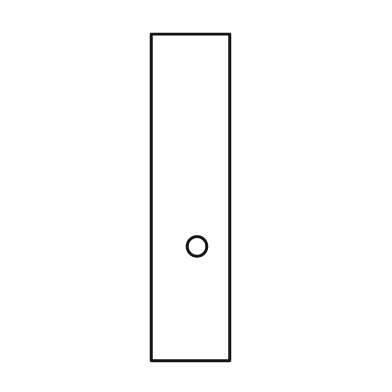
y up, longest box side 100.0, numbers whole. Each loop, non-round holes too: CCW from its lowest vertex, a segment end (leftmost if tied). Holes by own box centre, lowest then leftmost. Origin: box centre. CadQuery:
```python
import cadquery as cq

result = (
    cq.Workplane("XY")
    .moveTo(-12.0, -50.0)
    .lineTo(12.0, -50.0)
    .lineTo(12.0, 50.0)
    .lineTo(-12.0, 50.0)
    .close()
    .moveTo(2.0, -15.0)
    .circle(3.0)
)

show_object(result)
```